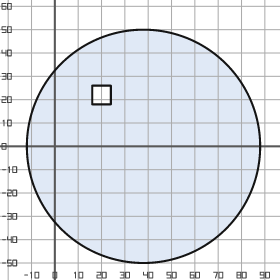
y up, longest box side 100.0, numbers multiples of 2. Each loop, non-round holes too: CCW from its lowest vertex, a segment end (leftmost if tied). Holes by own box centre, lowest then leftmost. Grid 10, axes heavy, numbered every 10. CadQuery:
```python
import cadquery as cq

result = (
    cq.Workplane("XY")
    .moveTo(38.0, 0.0)
    .circle(50.0)
    .moveTo(16.0, 18.0)
    .lineTo(24.0, 18.0)
    .lineTo(24.0, 26.0)
    .lineTo(16.0, 26.0)
    .close()
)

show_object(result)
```